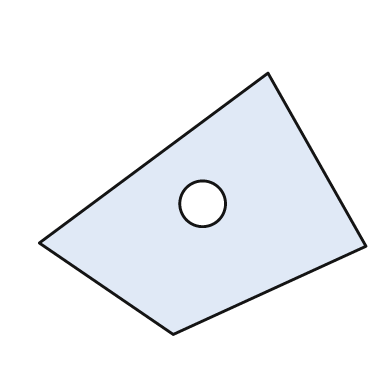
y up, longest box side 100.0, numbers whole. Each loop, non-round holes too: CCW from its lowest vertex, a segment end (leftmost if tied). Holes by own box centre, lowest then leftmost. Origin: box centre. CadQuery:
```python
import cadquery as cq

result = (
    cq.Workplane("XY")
    .moveTo(-9.0, -40.0)
    .lineTo(50.0, -13.0)
    .lineTo(20.0, 40.0)
    .lineTo(-50.0, -12.0)
    .close()
    .moveTo(0.0, 0.0)
    .circle(7.0)
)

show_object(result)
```